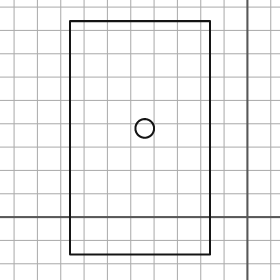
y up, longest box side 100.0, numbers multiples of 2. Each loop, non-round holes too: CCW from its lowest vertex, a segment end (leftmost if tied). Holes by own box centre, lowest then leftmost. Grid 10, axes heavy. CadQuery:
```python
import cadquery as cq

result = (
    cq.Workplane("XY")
    .moveTo(-76.0, -16.0)
    .lineTo(-16.0, -16.0)
    .lineTo(-16.0, 84.0)
    .lineTo(-76.0, 84.0)
    .close()
    .moveTo(-44.0, 38.0)
    .circle(4.0)
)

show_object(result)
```